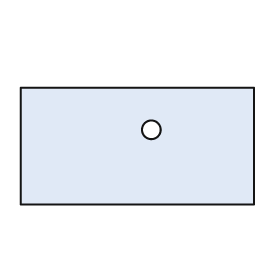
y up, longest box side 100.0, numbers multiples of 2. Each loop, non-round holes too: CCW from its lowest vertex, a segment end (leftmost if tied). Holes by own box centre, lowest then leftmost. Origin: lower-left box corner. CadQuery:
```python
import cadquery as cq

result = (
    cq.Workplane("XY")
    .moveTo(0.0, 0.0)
    .lineTo(100.0, 0.0)
    .lineTo(100.0, 50.0)
    .lineTo(0.0, 50.0)
    .close()
    .moveTo(56.0, 32.0)
    .circle(4.0)
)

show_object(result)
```